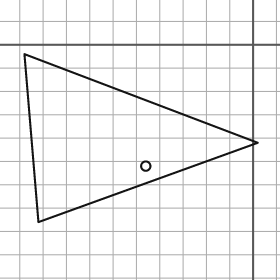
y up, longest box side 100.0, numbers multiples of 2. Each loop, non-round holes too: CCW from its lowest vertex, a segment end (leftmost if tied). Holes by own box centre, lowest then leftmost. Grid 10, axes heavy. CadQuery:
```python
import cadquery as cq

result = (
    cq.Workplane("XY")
    .moveTo(-92.0, -76.0)
    .lineTo(2.0, -42.0)
    .lineTo(-98.0, -4.0)
    .close()
    .moveTo(-46.0, -52.0)
    .circle(2.0)
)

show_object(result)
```